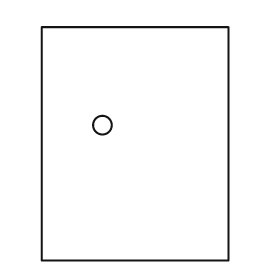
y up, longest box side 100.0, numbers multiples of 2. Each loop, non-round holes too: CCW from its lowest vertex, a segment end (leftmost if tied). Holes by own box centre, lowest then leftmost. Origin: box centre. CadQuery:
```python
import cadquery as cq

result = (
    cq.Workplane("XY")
    .moveTo(-40.0, -50.0)
    .lineTo(40.0, -50.0)
    .lineTo(40.0, 50.0)
    .lineTo(-40.0, 50.0)
    .close()
    .moveTo(-14.0, 8.0)
    .circle(4.0)
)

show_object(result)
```